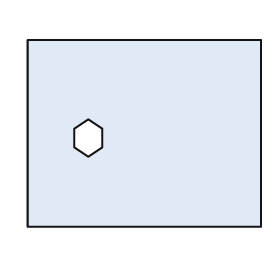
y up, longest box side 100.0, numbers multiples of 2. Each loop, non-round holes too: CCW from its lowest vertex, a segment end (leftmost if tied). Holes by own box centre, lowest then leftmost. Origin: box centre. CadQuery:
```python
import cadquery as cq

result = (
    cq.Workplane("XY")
    .moveTo(-50.0, -40.0)
    .lineTo(50.0, -40.0)
    .lineTo(50.0, 40.0)
    .lineTo(-50.0, 40.0)
    .close()
    .moveTo(-24.0, -10.0)
    .lineTo(-18.0, -6.0)
    .lineTo(-18.0, 2.0)
    .lineTo(-24.0, 6.0)
    .lineTo(-30.0, 2.0)
    .lineTo(-30.0, -6.0)
    .close()
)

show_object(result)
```